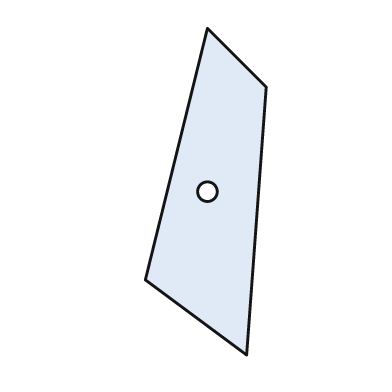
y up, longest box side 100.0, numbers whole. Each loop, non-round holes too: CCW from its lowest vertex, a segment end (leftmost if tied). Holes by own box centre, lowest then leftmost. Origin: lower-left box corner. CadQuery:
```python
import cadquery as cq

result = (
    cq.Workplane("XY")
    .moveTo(31.0, 0.0)
    .lineTo(37.0, 82.0)
    .lineTo(19.0, 100.0)
    .lineTo(0.0, 23.0)
    .close()
    .moveTo(19.0, 50.0)
    .circle(3.0)
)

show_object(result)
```